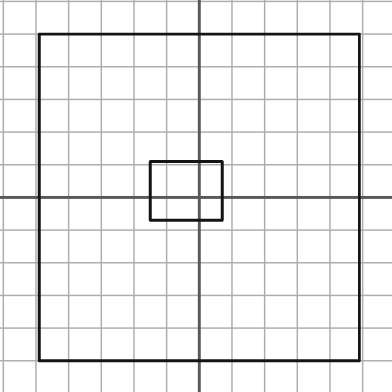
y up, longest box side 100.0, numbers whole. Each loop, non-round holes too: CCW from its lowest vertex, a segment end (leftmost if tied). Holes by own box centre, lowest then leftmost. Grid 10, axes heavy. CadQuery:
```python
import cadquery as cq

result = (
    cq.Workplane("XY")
    .moveTo(-49.0, -50.0)
    .lineTo(49.0, -50.0)
    .lineTo(49.0, 50.0)
    .lineTo(-49.0, 50.0)
    .close()
    .moveTo(-15.0, -7.0)
    .lineTo(7.0, -7.0)
    .lineTo(7.0, 11.0)
    .lineTo(-15.0, 11.0)
    .close()
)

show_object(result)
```